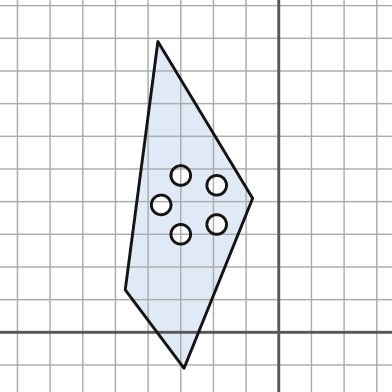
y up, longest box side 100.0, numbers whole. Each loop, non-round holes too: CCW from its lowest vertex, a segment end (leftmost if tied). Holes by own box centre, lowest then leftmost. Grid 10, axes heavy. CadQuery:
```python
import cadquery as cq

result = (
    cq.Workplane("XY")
    .moveTo(-29.0, -11.0)
    .lineTo(-8.0, 41.0)
    .lineTo(-37.0, 89.0)
    .lineTo(-47.0, 13.0)
    .close()
    .moveTo(-30.0, 30.0)
    .circle(3.0)
    .moveTo(-19.0, 33.0)
    .circle(3.0)
    .moveTo(-36.0, 39.0)
    .circle(3.0)
    .moveTo(-19.0, 45.0)
    .circle(3.0)
    .moveTo(-30.0, 48.0)
    .circle(3.0)
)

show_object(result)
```